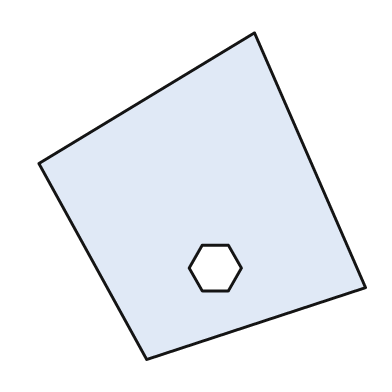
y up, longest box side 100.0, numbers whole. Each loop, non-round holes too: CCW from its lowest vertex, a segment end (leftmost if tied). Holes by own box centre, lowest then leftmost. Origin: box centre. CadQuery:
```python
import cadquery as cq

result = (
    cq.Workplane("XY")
    .moveTo(-17.0, -50.0)
    .lineTo(50.0, -28.0)
    .lineTo(16.0, 50.0)
    .lineTo(-50.0, 10.0)
    .close()
    .moveTo(0.0, -29.0)
    .lineTo(8.0, -29.0)
    .lineTo(12.0, -22.0)
    .lineTo(8.0, -15.0)
    .lineTo(0.0, -15.0)
    .lineTo(-4.0, -22.0)
    .close()
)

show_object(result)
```